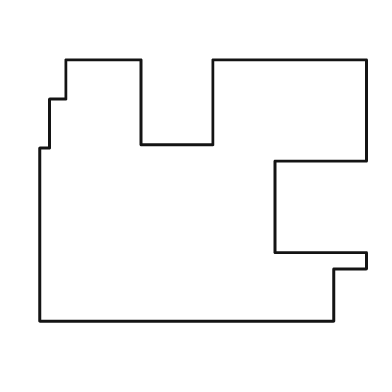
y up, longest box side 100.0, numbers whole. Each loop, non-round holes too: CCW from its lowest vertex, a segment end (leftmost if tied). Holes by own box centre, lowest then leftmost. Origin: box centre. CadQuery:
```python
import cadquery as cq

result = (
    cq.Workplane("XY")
    .moveTo(-50.0, -40.0)
    .lineTo(40.0, -40.0)
    .lineTo(40.0, -24.0)
    .lineTo(50.0, -24.0)
    .lineTo(50.0, -19.0)
    .lineTo(22.0, -19.0)
    .lineTo(22.0, 9.0)
    .lineTo(50.0, 9.0)
    .lineTo(50.0, 40.0)
    .lineTo(3.0, 40.0)
    .lineTo(3.0, 14.0)
    .lineTo(-19.0, 14.0)
    .lineTo(-19.0, 40.0)
    .lineTo(-42.0, 40.0)
    .lineTo(-42.0, 28.0)
    .lineTo(-47.0, 28.0)
    .lineTo(-47.0, 13.0)
    .lineTo(-50.0, 13.0)
    .close()
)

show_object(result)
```